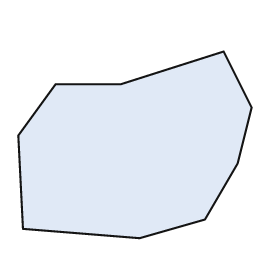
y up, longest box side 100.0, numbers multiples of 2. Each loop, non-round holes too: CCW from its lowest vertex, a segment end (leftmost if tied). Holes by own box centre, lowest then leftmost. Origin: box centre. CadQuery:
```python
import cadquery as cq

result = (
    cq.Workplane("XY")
    .moveTo(2.0, -40.0)
    .lineTo(30.0, -32.0)
    .lineTo(44.0, -8.0)
    .lineTo(50.0, 16.0)
    .lineTo(38.0, 40.0)
    .lineTo(-6.0, 26.0)
    .lineTo(-34.0, 26.0)
    .lineTo(-50.0, 4.0)
    .lineTo(-48.0, -36.0)
    .close()
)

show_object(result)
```